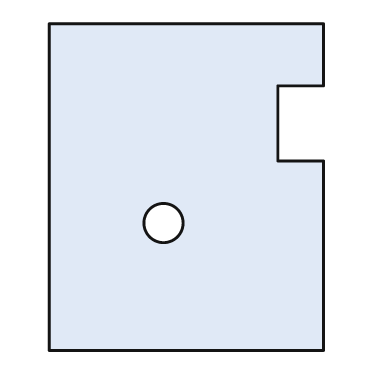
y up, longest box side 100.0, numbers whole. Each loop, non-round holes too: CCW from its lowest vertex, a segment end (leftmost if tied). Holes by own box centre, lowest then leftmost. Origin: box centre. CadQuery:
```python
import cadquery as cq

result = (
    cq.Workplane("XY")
    .moveTo(-42.0, -50.0)
    .lineTo(42.0, -50.0)
    .lineTo(42.0, 8.0)
    .lineTo(28.0, 8.0)
    .lineTo(28.0, 31.0)
    .lineTo(42.0, 31.0)
    .lineTo(42.0, 50.0)
    .lineTo(-42.0, 50.0)
    .close()
    .moveTo(-7.0, -11.0)
    .circle(6.0)
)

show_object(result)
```